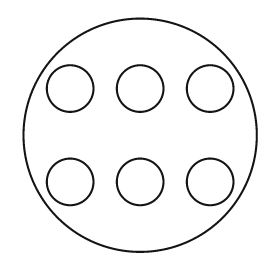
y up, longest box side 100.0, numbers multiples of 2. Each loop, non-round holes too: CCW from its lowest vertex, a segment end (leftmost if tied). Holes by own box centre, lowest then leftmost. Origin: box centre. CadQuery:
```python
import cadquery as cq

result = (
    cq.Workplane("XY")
    .moveTo(0.0, 0.0)
    .circle(50.0)
    .moveTo(-30.0, -20.0)
    .circle(10.0)
    .moveTo(0.0, -20.0)
    .circle(10.0)
    .moveTo(30.0, -20.0)
    .circle(10.0)
    .moveTo(-30.0, 20.0)
    .circle(10.0)
    .moveTo(0.0, 20.0)
    .circle(10.0)
    .moveTo(30.0, 20.0)
    .circle(10.0)
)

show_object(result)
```